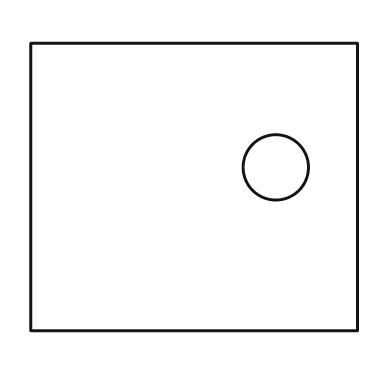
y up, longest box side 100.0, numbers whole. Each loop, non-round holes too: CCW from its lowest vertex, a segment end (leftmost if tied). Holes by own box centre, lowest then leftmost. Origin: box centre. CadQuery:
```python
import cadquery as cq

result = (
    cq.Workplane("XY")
    .moveTo(-50.0, -44.0)
    .lineTo(50.0, -44.0)
    .lineTo(50.0, 44.0)
    .lineTo(-50.0, 44.0)
    .close()
    .moveTo(25.0, 6.0)
    .circle(10.0)
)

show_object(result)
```